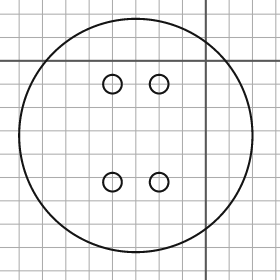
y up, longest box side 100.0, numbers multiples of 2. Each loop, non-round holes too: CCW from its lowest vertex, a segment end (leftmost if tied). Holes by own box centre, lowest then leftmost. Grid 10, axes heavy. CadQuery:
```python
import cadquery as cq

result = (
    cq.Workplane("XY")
    .moveTo(-30.0, -32.0)
    .circle(50.0)
    .moveTo(-40.0, -52.0)
    .circle(4.0)
    .moveTo(-20.0, -52.0)
    .circle(4.0)
    .moveTo(-40.0, -10.0)
    .circle(4.0)
    .moveTo(-20.0, -10.0)
    .circle(4.0)
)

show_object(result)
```